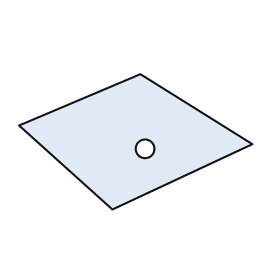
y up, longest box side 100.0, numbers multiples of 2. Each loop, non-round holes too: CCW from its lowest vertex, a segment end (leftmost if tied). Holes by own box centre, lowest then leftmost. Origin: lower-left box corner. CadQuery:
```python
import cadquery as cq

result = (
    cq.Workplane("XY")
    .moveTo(40.0, 0.0)
    .lineTo(100.0, 28.0)
    .lineTo(52.0, 58.0)
    .lineTo(0.0, 36.0)
    .close()
    .moveTo(54.0, 26.0)
    .circle(4.0)
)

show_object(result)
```